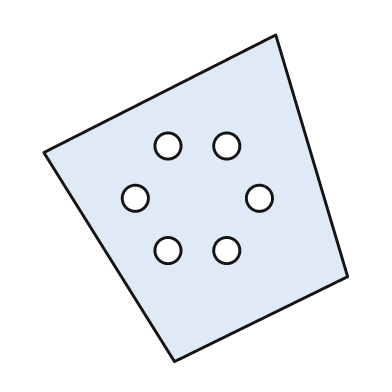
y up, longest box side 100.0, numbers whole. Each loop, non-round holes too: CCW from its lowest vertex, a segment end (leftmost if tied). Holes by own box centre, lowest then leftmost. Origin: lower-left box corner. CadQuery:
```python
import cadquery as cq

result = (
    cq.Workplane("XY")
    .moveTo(40.0, 0.0)
    .lineTo(93.0, 26.0)
    .lineTo(71.0, 100.0)
    .lineTo(0.0, 64.0)
    .close()
    .moveTo(38.0, 34.0)
    .circle(4.0)
    .moveTo(56.0, 34.0)
    .circle(4.0)
    .moveTo(28.0, 50.0)
    .circle(4.0)
    .moveTo(66.0, 50.0)
    .circle(4.0)
    .moveTo(38.0, 66.0)
    .circle(4.0)
    .moveTo(56.0, 66.0)
    .circle(4.0)
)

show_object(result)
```